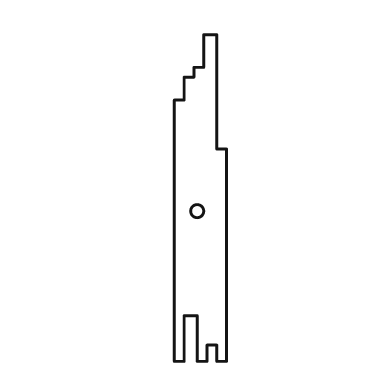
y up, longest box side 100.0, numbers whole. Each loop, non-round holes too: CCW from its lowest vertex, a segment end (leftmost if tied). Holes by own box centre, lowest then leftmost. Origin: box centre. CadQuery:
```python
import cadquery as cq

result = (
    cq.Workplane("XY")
    .moveTo(-8.0, -50.0)
    .lineTo(-5.0, -50.0)
    .lineTo(-5.0, -36.0)
    .lineTo(-1.0, -36.0)
    .lineTo(-1.0, -50.0)
    .lineTo(2.0, -50.0)
    .lineTo(2.0, -45.0)
    .lineTo(5.0, -45.0)
    .lineTo(5.0, -50.0)
    .lineTo(8.0, -50.0)
    .lineTo(8.0, 15.0)
    .lineTo(5.0, 15.0)
    .lineTo(5.0, 50.0)
    .lineTo(1.0, 50.0)
    .lineTo(1.0, 40.0)
    .lineTo(-2.0, 40.0)
    .lineTo(-2.0, 37.0)
    .lineTo(-5.0, 37.0)
    .lineTo(-5.0, 30.0)
    .lineTo(-8.0, 30.0)
    .close()
    .moveTo(-1.0, -4.0)
    .circle(2.0)
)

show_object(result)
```